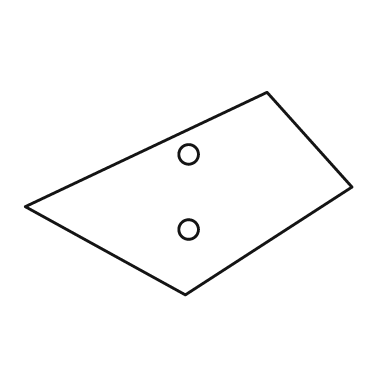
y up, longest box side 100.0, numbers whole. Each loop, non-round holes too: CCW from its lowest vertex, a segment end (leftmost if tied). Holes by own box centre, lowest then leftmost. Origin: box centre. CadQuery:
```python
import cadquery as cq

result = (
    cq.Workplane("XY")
    .moveTo(-1.0, -31.0)
    .lineTo(50.0, 2.0)
    .lineTo(24.0, 31.0)
    .lineTo(-50.0, -4.0)
    .close()
    .moveTo(0.0, -11.0)
    .circle(3.0)
    .moveTo(0.0, 12.0)
    .circle(3.0)
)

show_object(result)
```